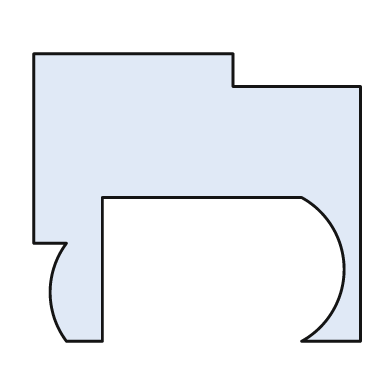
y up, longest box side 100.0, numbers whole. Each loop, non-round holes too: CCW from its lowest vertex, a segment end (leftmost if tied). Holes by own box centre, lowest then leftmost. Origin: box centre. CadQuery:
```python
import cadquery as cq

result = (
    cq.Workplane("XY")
    .moveTo(-40.0, -44.0)
    .lineTo(-29.0, -44.0)
    .lineTo(-29.0, 0.0)
    .lineTo(32.0, 0.0)
    .threePointArc((45.0, -22.0), (32.0, -44.0))
    .lineTo(50.0, -44.0)
    .lineTo(50.0, 34.0)
    .lineTo(11.0, 34.0)
    .lineTo(11.0, 44.0)
    .lineTo(-50.0, 44.0)
    .lineTo(-50.0, -14.0)
    .lineTo(-40.0, -14.0)
    .threePointArc((-45.0, -29.0), (-40.0, -44.0))
    .close()
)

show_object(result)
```